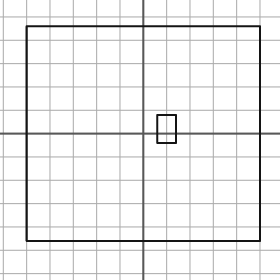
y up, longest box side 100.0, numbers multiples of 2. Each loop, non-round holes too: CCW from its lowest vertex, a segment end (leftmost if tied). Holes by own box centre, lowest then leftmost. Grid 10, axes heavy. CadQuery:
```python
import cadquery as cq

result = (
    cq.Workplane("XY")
    .moveTo(-50.0, -46.0)
    .lineTo(50.0, -46.0)
    .lineTo(50.0, 46.0)
    .lineTo(-50.0, 46.0)
    .close()
    .moveTo(6.0, -4.0)
    .lineTo(14.0, -4.0)
    .lineTo(14.0, 8.0)
    .lineTo(6.0, 8.0)
    .close()
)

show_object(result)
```